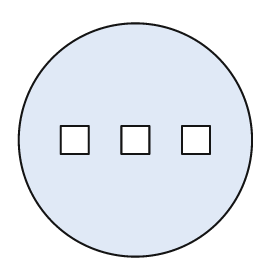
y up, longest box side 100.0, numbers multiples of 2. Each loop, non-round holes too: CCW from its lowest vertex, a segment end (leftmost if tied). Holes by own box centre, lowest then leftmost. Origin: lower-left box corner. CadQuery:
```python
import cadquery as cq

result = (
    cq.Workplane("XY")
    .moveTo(50.0, 50.0)
    .circle(50.0)
    .moveTo(18.0, 44.0)
    .lineTo(30.0, 44.0)
    .lineTo(30.0, 56.0)
    .lineTo(18.0, 56.0)
    .close()
    .moveTo(44.0, 44.0)
    .lineTo(56.0, 44.0)
    .lineTo(56.0, 56.0)
    .lineTo(44.0, 56.0)
    .close()
    .moveTo(70.0, 44.0)
    .lineTo(82.0, 44.0)
    .lineTo(82.0, 56.0)
    .lineTo(70.0, 56.0)
    .close()
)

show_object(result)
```